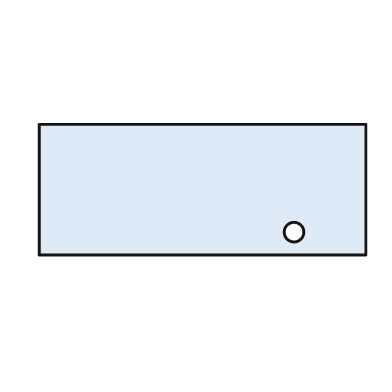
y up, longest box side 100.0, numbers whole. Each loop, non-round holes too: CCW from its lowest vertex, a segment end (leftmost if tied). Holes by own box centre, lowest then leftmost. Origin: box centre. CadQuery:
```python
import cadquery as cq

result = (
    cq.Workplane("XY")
    .moveTo(-50.0, -20.0)
    .lineTo(50.0, -20.0)
    .lineTo(50.0, 20.0)
    .lineTo(-50.0, 20.0)
    .close()
    .moveTo(28.0, -13.0)
    .circle(3.0)
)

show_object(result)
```